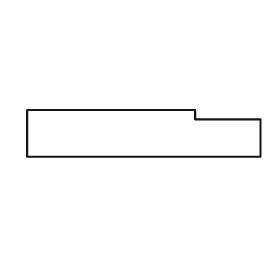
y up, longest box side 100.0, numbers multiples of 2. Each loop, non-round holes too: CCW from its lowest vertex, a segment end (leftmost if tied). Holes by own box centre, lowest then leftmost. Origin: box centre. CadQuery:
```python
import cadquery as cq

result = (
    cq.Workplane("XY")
    .moveTo(-50.0, -10.0)
    .lineTo(50.0, -10.0)
    .lineTo(50.0, 6.0)
    .lineTo(22.0, 6.0)
    .lineTo(22.0, 10.0)
    .lineTo(-50.0, 10.0)
    .close()
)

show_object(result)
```